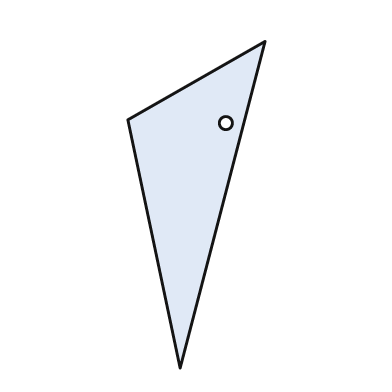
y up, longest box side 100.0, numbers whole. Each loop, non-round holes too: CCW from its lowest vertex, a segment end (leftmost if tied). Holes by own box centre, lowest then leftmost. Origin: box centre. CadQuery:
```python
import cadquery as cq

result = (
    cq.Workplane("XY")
    .moveTo(-5.0, -50.0)
    .lineTo(21.0, 50.0)
    .lineTo(-21.0, 26.0)
    .close()
    .moveTo(9.0, 25.0)
    .circle(2.0)
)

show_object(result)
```